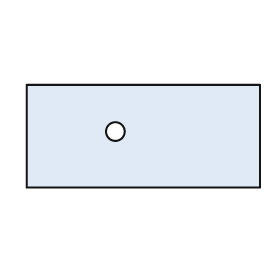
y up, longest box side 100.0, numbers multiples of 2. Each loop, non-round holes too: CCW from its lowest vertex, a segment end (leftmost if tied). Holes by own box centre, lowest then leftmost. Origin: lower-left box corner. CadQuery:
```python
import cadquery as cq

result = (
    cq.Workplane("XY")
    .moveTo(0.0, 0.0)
    .lineTo(100.0, 0.0)
    .lineTo(100.0, 44.0)
    .lineTo(0.0, 44.0)
    .close()
    .moveTo(38.0, 24.0)
    .circle(4.0)
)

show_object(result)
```